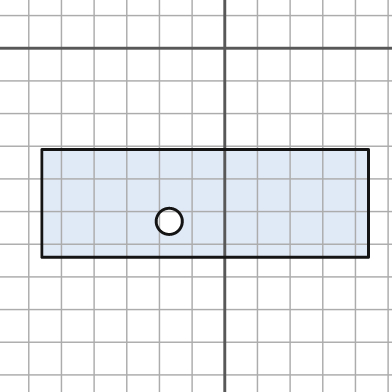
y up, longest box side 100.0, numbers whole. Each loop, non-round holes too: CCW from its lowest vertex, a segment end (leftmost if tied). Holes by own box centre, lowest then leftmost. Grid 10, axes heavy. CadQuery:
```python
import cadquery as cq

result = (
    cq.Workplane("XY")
    .moveTo(-56.0, -64.0)
    .lineTo(44.0, -64.0)
    .lineTo(44.0, -31.0)
    .lineTo(-56.0, -31.0)
    .close()
    .moveTo(-17.0, -53.0)
    .circle(4.0)
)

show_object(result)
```